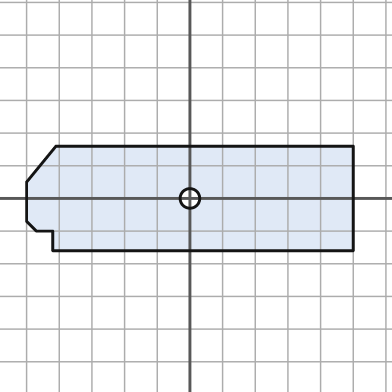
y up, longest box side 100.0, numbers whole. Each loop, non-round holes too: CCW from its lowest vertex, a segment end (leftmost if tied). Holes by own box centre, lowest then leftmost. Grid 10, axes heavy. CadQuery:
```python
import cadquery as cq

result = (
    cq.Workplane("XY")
    .moveTo(-42.0, -16.0)
    .lineTo(50.0, -16.0)
    .lineTo(50.0, 16.0)
    .lineTo(-41.0, 16.0)
    .lineTo(-50.0, 5.0)
    .lineTo(-50.0, -7.0)
    .lineTo(-47.0, -10.0)
    .lineTo(-42.0, -10.0)
    .close()
    .moveTo(0.0, 0.0)
    .circle(3.0)
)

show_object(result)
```